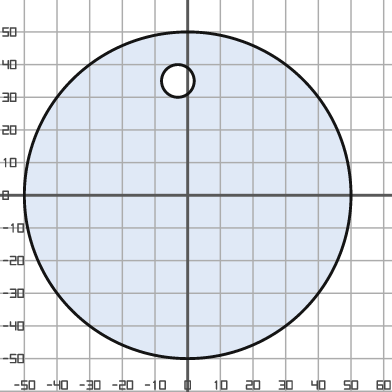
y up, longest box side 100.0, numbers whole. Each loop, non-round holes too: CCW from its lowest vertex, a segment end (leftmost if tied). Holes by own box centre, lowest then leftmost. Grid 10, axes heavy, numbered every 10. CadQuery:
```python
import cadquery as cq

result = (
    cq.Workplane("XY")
    .moveTo(0.0, 0.0)
    .circle(50.0)
    .moveTo(-3.0, 35.0)
    .circle(5.0)
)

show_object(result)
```